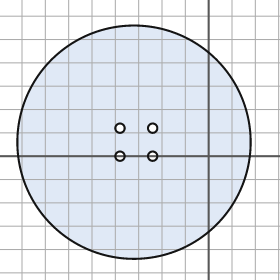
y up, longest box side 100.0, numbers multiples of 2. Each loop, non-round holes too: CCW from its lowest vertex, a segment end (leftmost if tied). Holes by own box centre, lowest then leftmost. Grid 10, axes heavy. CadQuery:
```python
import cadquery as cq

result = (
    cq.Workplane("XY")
    .moveTo(-32.0, 6.0)
    .circle(50.0)
    .moveTo(-38.0, 0.0)
    .circle(2.0)
    .moveTo(-24.0, 0.0)
    .circle(2.0)
    .moveTo(-38.0, 12.0)
    .circle(2.0)
    .moveTo(-24.0, 12.0)
    .circle(2.0)
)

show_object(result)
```